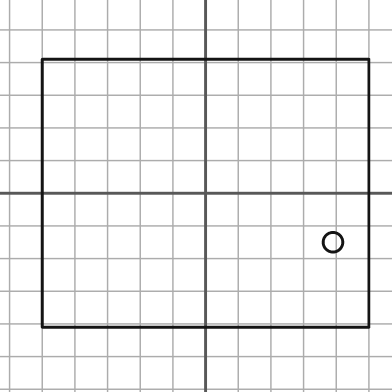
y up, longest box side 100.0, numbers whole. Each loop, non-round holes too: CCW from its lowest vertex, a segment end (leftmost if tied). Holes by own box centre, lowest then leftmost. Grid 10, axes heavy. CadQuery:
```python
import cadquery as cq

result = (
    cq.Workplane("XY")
    .moveTo(-50.0, -41.0)
    .lineTo(50.0, -41.0)
    .lineTo(50.0, 41.0)
    .lineTo(-50.0, 41.0)
    .close()
    .moveTo(39.0, -15.0)
    .circle(3.0)
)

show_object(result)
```